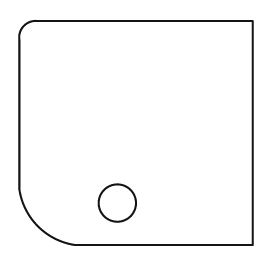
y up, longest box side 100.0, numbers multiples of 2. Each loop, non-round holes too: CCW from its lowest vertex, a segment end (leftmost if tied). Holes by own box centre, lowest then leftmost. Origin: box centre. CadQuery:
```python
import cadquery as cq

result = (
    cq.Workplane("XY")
    .moveTo(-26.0, -48.0)
    .lineTo(50.0, -48.0)
    .lineTo(50.0, 48.0)
    .lineTo(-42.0, 48.0)
    .threePointArc((-48.0, 46.0), (-50.0, 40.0))
    .lineTo(-50.0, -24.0)
    .threePointArc((-42.0, -40.0), (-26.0, -48.0))
    .close()
    .moveTo(-8.0, -30.0)
    .circle(8.0)
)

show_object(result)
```